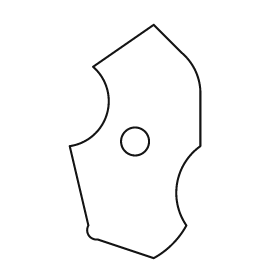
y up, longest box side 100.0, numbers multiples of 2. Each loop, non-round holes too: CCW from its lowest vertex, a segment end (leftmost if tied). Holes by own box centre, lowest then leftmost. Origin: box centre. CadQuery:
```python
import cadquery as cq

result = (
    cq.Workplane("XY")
    .moveTo(8.0, -50.0)
    .threePointArc((16.0, -44.0), (22.0, -36.0))
    .threePointArc((18.0, -18.0), (28.0, -2.0))
    .lineTo(28.0, 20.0)
    .threePointArc((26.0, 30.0), (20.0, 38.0))
    .lineTo(8.0, 50.0)
    .lineTo(-18.0, 32.0)
    .threePointArc((-12.0, 12.0), (-28.0, -2.0))
    .lineTo(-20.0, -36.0)
    .threePointArc((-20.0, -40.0), (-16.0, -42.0))
    .close()
    .moveTo(0.0, 0.0)
    .circle(6.0)
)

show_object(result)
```